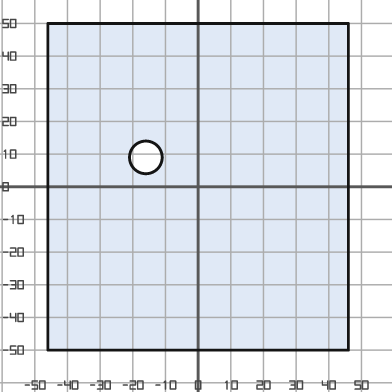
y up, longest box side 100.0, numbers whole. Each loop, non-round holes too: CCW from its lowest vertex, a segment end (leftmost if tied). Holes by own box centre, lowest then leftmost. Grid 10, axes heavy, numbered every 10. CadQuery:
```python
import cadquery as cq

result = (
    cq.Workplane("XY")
    .moveTo(-46.0, -50.0)
    .lineTo(46.0, -50.0)
    .lineTo(46.0, 50.0)
    .lineTo(-46.0, 50.0)
    .close()
    .moveTo(-16.0, 9.0)
    .circle(5.0)
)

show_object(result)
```